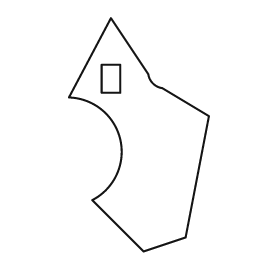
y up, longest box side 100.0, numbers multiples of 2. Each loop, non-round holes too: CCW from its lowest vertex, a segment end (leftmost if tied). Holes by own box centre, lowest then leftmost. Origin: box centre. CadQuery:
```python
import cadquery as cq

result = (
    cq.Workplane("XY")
    .moveTo(2.0, -50.0)
    .lineTo(20.0, -44.0)
    .lineTo(30.0, 8.0)
    .lineTo(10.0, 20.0)
    .threePointArc((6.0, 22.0), (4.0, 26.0))
    .lineTo(-12.0, 50.0)
    .lineTo(-30.0, 16.0)
    .threePointArc((-8.0, -2.0), (-20.0, -28.0))
    .close()
    .moveTo(-16.0, 18.0)
    .lineTo(-8.0, 18.0)
    .lineTo(-8.0, 30.0)
    .lineTo(-16.0, 30.0)
    .close()
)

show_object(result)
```